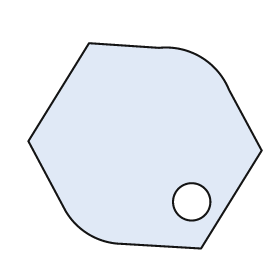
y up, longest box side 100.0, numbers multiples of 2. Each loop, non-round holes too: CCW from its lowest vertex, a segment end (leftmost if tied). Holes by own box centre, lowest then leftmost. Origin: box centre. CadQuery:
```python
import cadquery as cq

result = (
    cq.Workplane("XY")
    .moveTo(24.0, -44.0)
    .lineTo(50.0, -2.0)
    .lineTo(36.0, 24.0)
    .threePointArc((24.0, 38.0), (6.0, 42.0))
    .lineTo(-24.0, 44.0)
    .lineTo(-50.0, 2.0)
    .lineTo(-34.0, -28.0)
    .threePointArc((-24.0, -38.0), (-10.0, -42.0))
    .close()
    .moveTo(20.0, -24.0)
    .circle(8.0)
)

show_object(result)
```